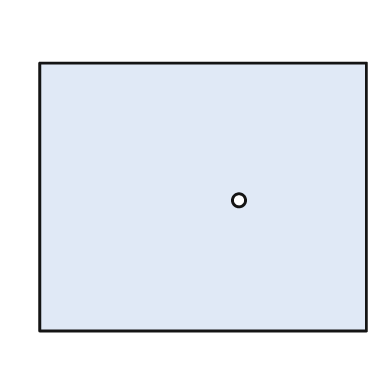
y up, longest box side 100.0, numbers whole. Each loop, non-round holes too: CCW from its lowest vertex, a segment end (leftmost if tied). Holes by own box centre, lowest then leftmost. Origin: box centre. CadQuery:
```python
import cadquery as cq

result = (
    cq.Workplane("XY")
    .moveTo(-50.0, -41.0)
    .lineTo(50.0, -41.0)
    .lineTo(50.0, 41.0)
    .lineTo(-50.0, 41.0)
    .close()
    .moveTo(11.0, -1.0)
    .circle(2.0)
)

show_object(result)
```